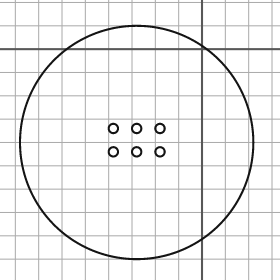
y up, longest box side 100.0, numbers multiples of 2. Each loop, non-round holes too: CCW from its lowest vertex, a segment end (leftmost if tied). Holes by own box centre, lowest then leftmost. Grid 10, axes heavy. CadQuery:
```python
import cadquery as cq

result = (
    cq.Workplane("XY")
    .moveTo(-28.0, -40.0)
    .circle(50.0)
    .moveTo(-38.0, -44.0)
    .circle(2.0)
    .moveTo(-28.0, -44.0)
    .circle(2.0)
    .moveTo(-18.0, -44.0)
    .circle(2.0)
    .moveTo(-38.0, -34.0)
    .circle(2.0)
    .moveTo(-28.0, -34.0)
    .circle(2.0)
    .moveTo(-18.0, -34.0)
    .circle(2.0)
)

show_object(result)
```